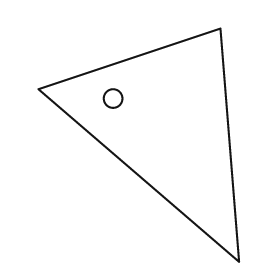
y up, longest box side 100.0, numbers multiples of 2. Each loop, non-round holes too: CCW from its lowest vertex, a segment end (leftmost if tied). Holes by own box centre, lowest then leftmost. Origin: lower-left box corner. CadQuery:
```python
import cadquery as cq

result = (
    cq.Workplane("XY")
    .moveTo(86.0, 0.0)
    .lineTo(78.0, 100.0)
    .lineTo(0.0, 74.0)
    .close()
    .moveTo(32.0, 70.0)
    .circle(4.0)
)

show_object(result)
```